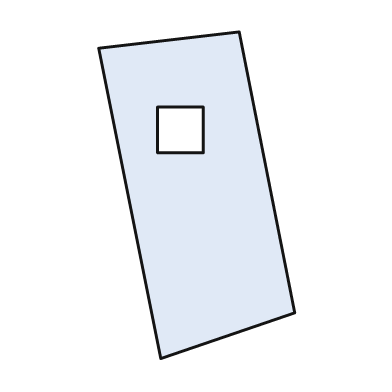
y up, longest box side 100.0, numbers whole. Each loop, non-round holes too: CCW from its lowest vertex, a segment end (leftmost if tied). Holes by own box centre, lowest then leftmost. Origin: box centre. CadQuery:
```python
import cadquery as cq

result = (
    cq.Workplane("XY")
    .moveTo(-11.0, -50.0)
    .lineTo(30.0, -36.0)
    .lineTo(13.0, 50.0)
    .lineTo(-30.0, 45.0)
    .close()
    .moveTo(-12.0, 13.0)
    .lineTo(2.0, 13.0)
    .lineTo(2.0, 27.0)
    .lineTo(-12.0, 27.0)
    .close()
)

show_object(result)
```